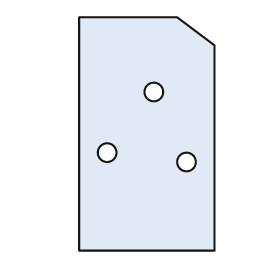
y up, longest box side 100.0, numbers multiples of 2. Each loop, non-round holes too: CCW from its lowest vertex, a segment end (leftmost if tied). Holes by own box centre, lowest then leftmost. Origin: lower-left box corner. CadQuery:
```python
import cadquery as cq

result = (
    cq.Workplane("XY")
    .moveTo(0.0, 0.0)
    .lineTo(58.0, 0.0)
    .lineTo(58.0, 88.0)
    .lineTo(42.0, 100.0)
    .lineTo(0.0, 100.0)
    .close()
    .moveTo(46.0, 38.0)
    .circle(4.0)
    .moveTo(12.0, 42.0)
    .circle(4.0)
    .moveTo(32.0, 68.0)
    .circle(4.0)
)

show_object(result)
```